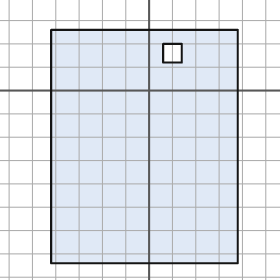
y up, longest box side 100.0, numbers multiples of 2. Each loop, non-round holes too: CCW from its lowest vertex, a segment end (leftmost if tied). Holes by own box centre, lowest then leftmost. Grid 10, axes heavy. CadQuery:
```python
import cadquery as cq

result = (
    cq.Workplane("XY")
    .moveTo(-42.0, -74.0)
    .lineTo(38.0, -74.0)
    .lineTo(38.0, 26.0)
    .lineTo(-42.0, 26.0)
    .close()
    .moveTo(6.0, 12.0)
    .lineTo(14.0, 12.0)
    .lineTo(14.0, 20.0)
    .lineTo(6.0, 20.0)
    .close()
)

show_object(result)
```